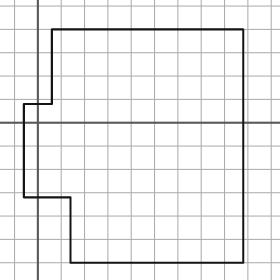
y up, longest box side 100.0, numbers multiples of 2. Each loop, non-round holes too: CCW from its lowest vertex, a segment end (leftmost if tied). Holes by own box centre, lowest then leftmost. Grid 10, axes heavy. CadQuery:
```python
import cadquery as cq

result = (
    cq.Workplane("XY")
    .moveTo(14.0, -60.0)
    .lineTo(88.0, -60.0)
    .lineTo(88.0, 40.0)
    .lineTo(6.0, 40.0)
    .lineTo(6.0, 8.0)
    .lineTo(-6.0, 8.0)
    .lineTo(-6.0, -32.0)
    .lineTo(14.0, -32.0)
    .close()
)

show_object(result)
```